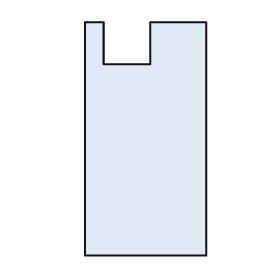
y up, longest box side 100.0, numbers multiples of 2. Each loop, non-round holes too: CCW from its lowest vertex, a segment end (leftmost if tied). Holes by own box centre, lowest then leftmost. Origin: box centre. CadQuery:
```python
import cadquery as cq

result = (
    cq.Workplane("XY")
    .moveTo(-26.0, -50.0)
    .lineTo(26.0, -50.0)
    .lineTo(26.0, 50.0)
    .lineTo(2.0, 50.0)
    .lineTo(2.0, 32.0)
    .lineTo(-18.0, 32.0)
    .lineTo(-18.0, 50.0)
    .lineTo(-26.0, 50.0)
    .close()
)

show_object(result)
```